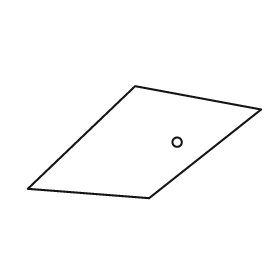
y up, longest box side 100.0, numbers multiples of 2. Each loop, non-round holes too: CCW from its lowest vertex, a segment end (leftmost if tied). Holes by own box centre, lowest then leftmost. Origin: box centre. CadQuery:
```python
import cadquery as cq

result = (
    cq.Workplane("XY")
    .moveTo(2.0, -24.0)
    .lineTo(50.0, 14.0)
    .lineTo(-4.0, 24.0)
    .lineTo(-50.0, -20.0)
    .close()
    .moveTo(14.0, 0.0)
    .circle(2.0)
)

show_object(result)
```